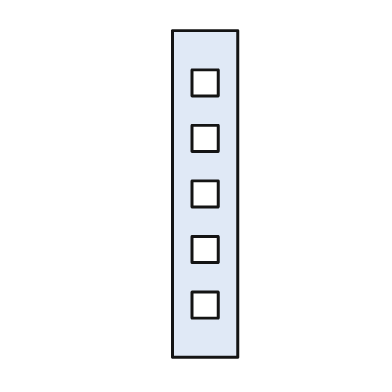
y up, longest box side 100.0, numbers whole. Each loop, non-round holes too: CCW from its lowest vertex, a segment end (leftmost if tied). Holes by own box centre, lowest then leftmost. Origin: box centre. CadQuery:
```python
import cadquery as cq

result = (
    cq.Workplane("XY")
    .moveTo(-10.0, -50.0)
    .lineTo(10.0, -50.0)
    .lineTo(10.0, 50.0)
    .lineTo(-10.0, 50.0)
    .close()
    .moveTo(-4.0, -38.0)
    .lineTo(4.0, -38.0)
    .lineTo(4.0, -30.0)
    .lineTo(-4.0, -30.0)
    .close()
    .moveTo(-4.0, -21.0)
    .lineTo(4.0, -21.0)
    .lineTo(4.0, -13.0)
    .lineTo(-4.0, -13.0)
    .close()
    .moveTo(-4.0, -4.0)
    .lineTo(4.0, -4.0)
    .lineTo(4.0, 4.0)
    .lineTo(-4.0, 4.0)
    .close()
    .moveTo(-4.0, 13.0)
    .lineTo(4.0, 13.0)
    .lineTo(4.0, 21.0)
    .lineTo(-4.0, 21.0)
    .close()
    .moveTo(-4.0, 30.0)
    .lineTo(4.0, 30.0)
    .lineTo(4.0, 38.0)
    .lineTo(-4.0, 38.0)
    .close()
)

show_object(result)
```